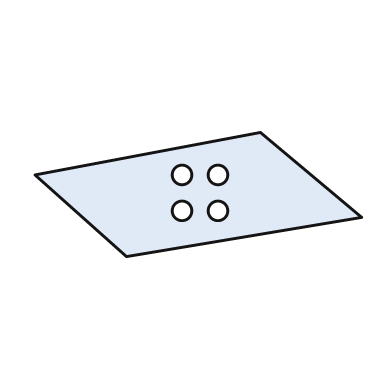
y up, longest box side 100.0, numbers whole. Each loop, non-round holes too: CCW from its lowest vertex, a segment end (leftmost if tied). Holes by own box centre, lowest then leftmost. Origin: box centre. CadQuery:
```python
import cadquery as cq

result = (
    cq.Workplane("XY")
    .moveTo(-22.0, -19.0)
    .lineTo(50.0, -7.0)
    .lineTo(19.0, 19.0)
    .lineTo(-50.0, 6.0)
    .close()
    .moveTo(-5.0, -5.0)
    .circle(3.0)
    .moveTo(6.0, -5.0)
    .circle(3.0)
    .moveTo(-5.0, 6.0)
    .circle(3.0)
    .moveTo(6.0, 6.0)
    .circle(3.0)
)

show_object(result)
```